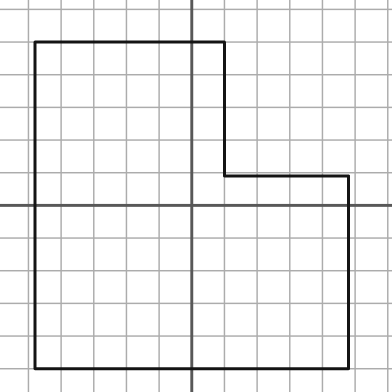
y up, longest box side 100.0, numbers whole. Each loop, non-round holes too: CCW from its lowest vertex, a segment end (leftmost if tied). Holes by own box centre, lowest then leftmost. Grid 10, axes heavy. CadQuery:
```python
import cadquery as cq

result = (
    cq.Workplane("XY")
    .moveTo(-48.0, -50.0)
    .lineTo(48.0, -50.0)
    .lineTo(48.0, 9.0)
    .lineTo(10.0, 9.0)
    .lineTo(10.0, 50.0)
    .lineTo(-48.0, 50.0)
    .close()
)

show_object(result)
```